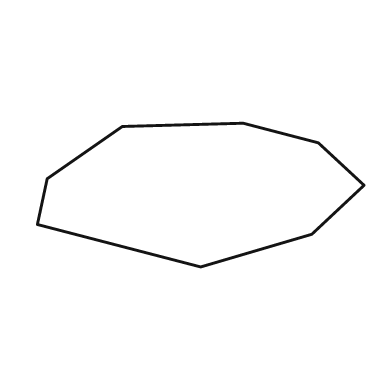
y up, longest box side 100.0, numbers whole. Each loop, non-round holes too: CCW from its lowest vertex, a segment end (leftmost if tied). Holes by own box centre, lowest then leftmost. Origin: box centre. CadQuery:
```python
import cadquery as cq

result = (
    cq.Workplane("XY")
    .moveTo(0.0, -22.0)
    .lineTo(34.0, -12.0)
    .lineTo(50.0, 3.0)
    .lineTo(36.0, 16.0)
    .lineTo(13.0, 22.0)
    .lineTo(-24.0, 21.0)
    .lineTo(-47.0, 5.0)
    .lineTo(-50.0, -9.0)
    .close()
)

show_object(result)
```